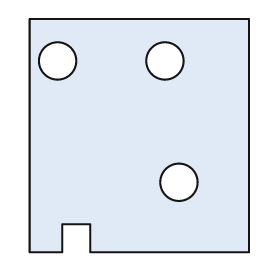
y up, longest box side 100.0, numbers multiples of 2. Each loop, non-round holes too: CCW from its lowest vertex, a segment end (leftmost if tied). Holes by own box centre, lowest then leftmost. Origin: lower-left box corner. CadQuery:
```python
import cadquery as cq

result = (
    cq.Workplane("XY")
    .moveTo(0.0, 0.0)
    .lineTo(14.0, 0.0)
    .lineTo(14.0, 12.0)
    .lineTo(26.0, 12.0)
    .lineTo(26.0, 0.0)
    .lineTo(94.0, 0.0)
    .lineTo(94.0, 100.0)
    .lineTo(0.0, 100.0)
    .close()
    .moveTo(64.0, 30.0)
    .circle(8.0)
    .moveTo(12.0, 82.0)
    .circle(8.0)
    .moveTo(58.0, 82.0)
    .circle(8.0)
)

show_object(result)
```